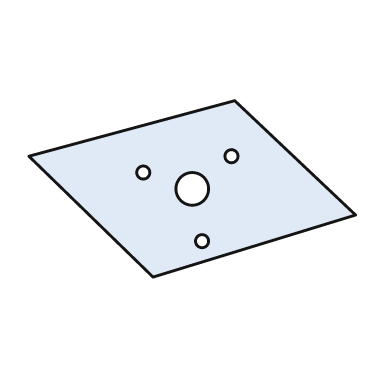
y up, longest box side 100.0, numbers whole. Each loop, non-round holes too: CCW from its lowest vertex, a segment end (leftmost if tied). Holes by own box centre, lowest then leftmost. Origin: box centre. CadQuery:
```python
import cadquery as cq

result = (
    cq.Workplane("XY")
    .moveTo(-12.0, -27.0)
    .lineTo(50.0, -8.0)
    .lineTo(13.0, 27.0)
    .lineTo(-50.0, 10.0)
    .close()
    .moveTo(3.0, -16.0)
    .circle(2.0)
    .moveTo(0.0, 0.0)
    .circle(5.0)
    .moveTo(-15.0, 5.0)
    .circle(2.0)
    .moveTo(12.0, 10.0)
    .circle(2.0)
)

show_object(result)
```